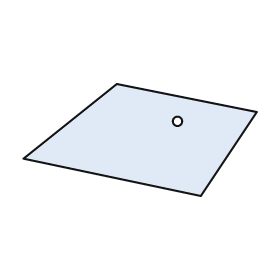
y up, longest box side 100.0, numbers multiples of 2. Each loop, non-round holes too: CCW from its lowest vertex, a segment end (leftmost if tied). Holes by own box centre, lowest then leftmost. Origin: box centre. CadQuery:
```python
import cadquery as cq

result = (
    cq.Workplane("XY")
    .moveTo(26.0, -24.0)
    .lineTo(50.0, 12.0)
    .lineTo(-10.0, 24.0)
    .lineTo(-50.0, -8.0)
    .close()
    .moveTo(16.0, 8.0)
    .circle(2.0)
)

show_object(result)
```